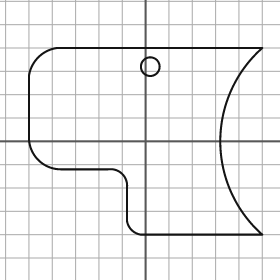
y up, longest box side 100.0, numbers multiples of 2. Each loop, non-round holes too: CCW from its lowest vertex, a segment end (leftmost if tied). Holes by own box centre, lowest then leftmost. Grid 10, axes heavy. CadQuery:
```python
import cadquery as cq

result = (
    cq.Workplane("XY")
    .moveTo(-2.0, -40.0)
    .lineTo(50.0, -40.0)
    .threePointArc((32.0, 0.0), (50.0, 40.0))
    .lineTo(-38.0, 40.0)
    .threePointArc((-46.0, 36.0), (-50.0, 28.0))
    .lineTo(-50.0, 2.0)
    .threePointArc((-46.0, -8.0), (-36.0, -12.0))
    .lineTo(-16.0, -12.0)
    .threePointArc((-10.0, -14.0), (-8.0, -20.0))
    .lineTo(-8.0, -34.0)
    .threePointArc((-6.0, -38.0), (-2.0, -40.0))
    .close()
    .moveTo(2.0, 32.0)
    .circle(4.0)
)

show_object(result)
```